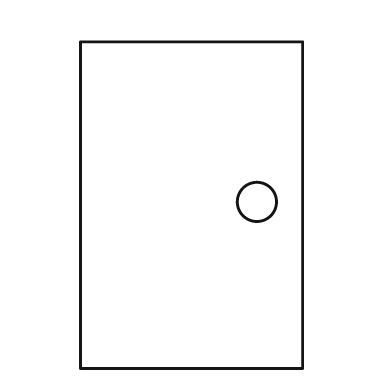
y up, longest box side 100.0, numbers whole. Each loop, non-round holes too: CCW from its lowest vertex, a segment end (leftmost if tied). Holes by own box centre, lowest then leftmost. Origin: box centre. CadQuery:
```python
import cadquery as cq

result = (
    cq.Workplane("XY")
    .moveTo(-34.0, -50.0)
    .lineTo(34.0, -50.0)
    .lineTo(34.0, 50.0)
    .lineTo(-34.0, 50.0)
    .close()
    .moveTo(20.0, 1.0)
    .circle(6.0)
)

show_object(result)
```